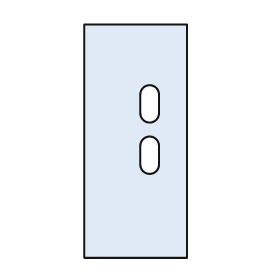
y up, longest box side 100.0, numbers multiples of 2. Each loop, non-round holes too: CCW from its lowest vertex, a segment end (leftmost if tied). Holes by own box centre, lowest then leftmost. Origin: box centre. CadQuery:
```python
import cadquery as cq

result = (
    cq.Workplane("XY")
    .moveTo(-22.0, -50.0)
    .lineTo(22.0, -50.0)
    .lineTo(22.0, 50.0)
    .lineTo(-22.0, 50.0)
    .close()
    .moveTo(2.0, -10.0)
    .threePointArc((6.0, -14.0), (10.0, -10.0))
    .lineTo(10.0, -2.0)
    .threePointArc((6.0, 2.0), (2.0, -2.0))
    .close()
    .moveTo(2.0, 12.0)
    .threePointArc((6.0, 8.0), (10.0, 12.0))
    .lineTo(10.0, 20.0)
    .threePointArc((6.0, 24.0), (2.0, 20.0))
    .close()
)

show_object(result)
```